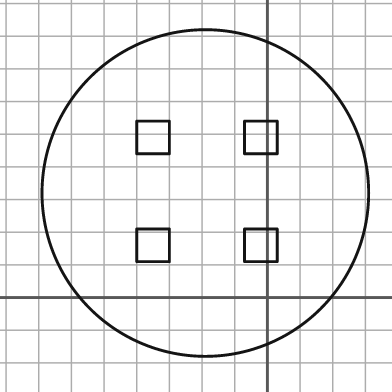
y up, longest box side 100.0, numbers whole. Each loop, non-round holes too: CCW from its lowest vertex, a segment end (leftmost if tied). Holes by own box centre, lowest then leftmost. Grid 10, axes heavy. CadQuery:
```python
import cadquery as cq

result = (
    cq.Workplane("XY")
    .moveTo(-19.0, 32.0)
    .circle(50.0)
    .moveTo(-40.0, 11.0)
    .lineTo(-30.0, 11.0)
    .lineTo(-30.0, 21.0)
    .lineTo(-40.0, 21.0)
    .close()
    .moveTo(-7.0, 11.0)
    .lineTo(3.0, 11.0)
    .lineTo(3.0, 21.0)
    .lineTo(-7.0, 21.0)
    .close()
    .moveTo(-40.0, 44.0)
    .lineTo(-30.0, 44.0)
    .lineTo(-30.0, 54.0)
    .lineTo(-40.0, 54.0)
    .close()
    .moveTo(-7.0, 44.0)
    .lineTo(3.0, 44.0)
    .lineTo(3.0, 54.0)
    .lineTo(-7.0, 54.0)
    .close()
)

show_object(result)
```